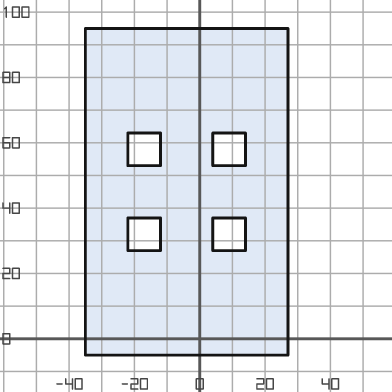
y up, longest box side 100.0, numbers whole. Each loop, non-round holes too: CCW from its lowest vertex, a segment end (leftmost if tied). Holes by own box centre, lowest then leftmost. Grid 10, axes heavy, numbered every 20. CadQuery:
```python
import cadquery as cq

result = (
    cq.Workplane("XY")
    .moveTo(-35.0, -5.0)
    .lineTo(27.0, -5.0)
    .lineTo(27.0, 95.0)
    .lineTo(-35.0, 95.0)
    .close()
    .moveTo(-22.0, 27.0)
    .lineTo(-12.0, 27.0)
    .lineTo(-12.0, 37.0)
    .lineTo(-22.0, 37.0)
    .close()
    .moveTo(4.0, 27.0)
    .lineTo(14.0, 27.0)
    .lineTo(14.0, 37.0)
    .lineTo(4.0, 37.0)
    .close()
    .moveTo(-22.0, 53.0)
    .lineTo(-12.0, 53.0)
    .lineTo(-12.0, 63.0)
    .lineTo(-22.0, 63.0)
    .close()
    .moveTo(4.0, 53.0)
    .lineTo(14.0, 53.0)
    .lineTo(14.0, 63.0)
    .lineTo(4.0, 63.0)
    .close()
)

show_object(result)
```